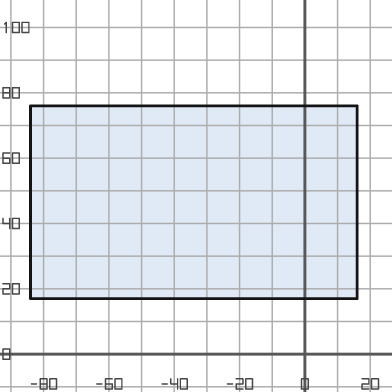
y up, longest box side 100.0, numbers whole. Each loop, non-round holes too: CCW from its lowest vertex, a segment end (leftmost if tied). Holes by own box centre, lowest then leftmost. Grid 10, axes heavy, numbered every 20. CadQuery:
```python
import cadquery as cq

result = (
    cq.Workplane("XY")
    .moveTo(-84.0, 17.0)
    .lineTo(16.0, 17.0)
    .lineTo(16.0, 76.0)
    .lineTo(-84.0, 76.0)
    .close()
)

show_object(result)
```